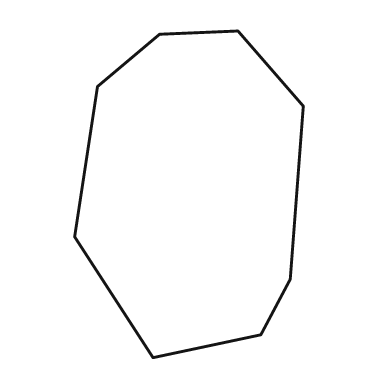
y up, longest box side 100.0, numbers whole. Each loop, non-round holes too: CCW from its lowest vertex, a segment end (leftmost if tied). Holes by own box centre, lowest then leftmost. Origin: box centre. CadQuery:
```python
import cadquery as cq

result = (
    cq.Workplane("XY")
    .moveTo(-11.0, -50.0)
    .lineTo(22.0, -43.0)
    .lineTo(31.0, -26.0)
    .lineTo(35.0, 27.0)
    .lineTo(15.0, 50.0)
    .lineTo(-9.0, 49.0)
    .lineTo(-28.0, 33.0)
    .lineTo(-35.0, -13.0)
    .close()
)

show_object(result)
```